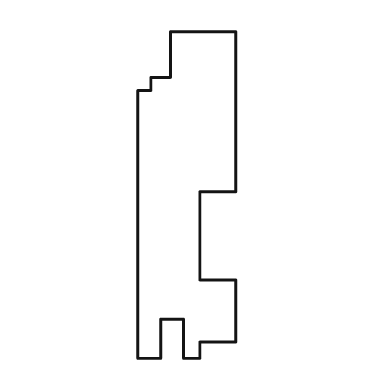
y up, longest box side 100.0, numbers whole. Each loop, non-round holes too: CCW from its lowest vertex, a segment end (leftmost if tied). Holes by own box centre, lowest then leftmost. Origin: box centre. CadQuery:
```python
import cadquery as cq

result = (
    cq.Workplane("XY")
    .moveTo(-15.0, -50.0)
    .lineTo(-8.0, -50.0)
    .lineTo(-8.0, -38.0)
    .lineTo(-1.0, -38.0)
    .lineTo(-1.0, -50.0)
    .lineTo(4.0, -50.0)
    .lineTo(4.0, -45.0)
    .lineTo(15.0, -45.0)
    .lineTo(15.0, -26.0)
    .lineTo(4.0, -26.0)
    .lineTo(4.0, 1.0)
    .lineTo(15.0, 1.0)
    .lineTo(15.0, 50.0)
    .lineTo(-5.0, 50.0)
    .lineTo(-5.0, 36.0)
    .lineTo(-11.0, 36.0)
    .lineTo(-11.0, 32.0)
    .lineTo(-15.0, 32.0)
    .close()
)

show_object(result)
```